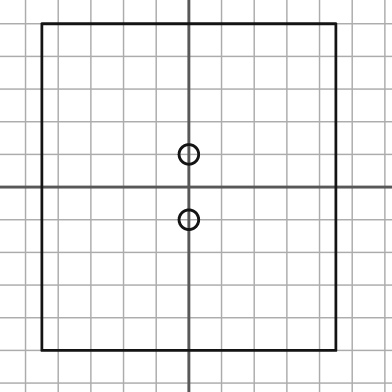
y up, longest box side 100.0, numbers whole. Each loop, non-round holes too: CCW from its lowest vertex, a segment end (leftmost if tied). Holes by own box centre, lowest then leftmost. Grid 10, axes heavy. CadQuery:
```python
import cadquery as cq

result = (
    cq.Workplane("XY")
    .moveTo(-45.0, -50.0)
    .lineTo(45.0, -50.0)
    .lineTo(45.0, 50.0)
    .lineTo(-45.0, 50.0)
    .close()
    .moveTo(0.0, -10.0)
    .circle(3.0)
    .moveTo(0.0, 10.0)
    .circle(3.0)
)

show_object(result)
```